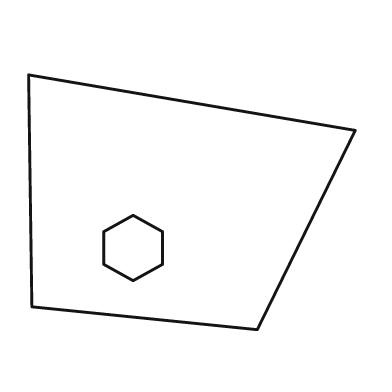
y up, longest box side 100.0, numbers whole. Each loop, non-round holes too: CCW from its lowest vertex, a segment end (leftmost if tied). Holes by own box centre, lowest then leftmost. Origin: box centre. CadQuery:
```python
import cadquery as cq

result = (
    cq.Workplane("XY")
    .moveTo(20.0, -39.0)
    .lineTo(50.0, 22.0)
    .lineTo(-50.0, 39.0)
    .lineTo(-49.0, -32.0)
    .close()
    .moveTo(-18.0, -24.0)
    .lineTo(-9.0, -19.0)
    .lineTo(-9.0, -9.0)
    .lineTo(-18.0, -4.0)
    .lineTo(-27.0, -9.0)
    .lineTo(-27.0, -19.0)
    .close()
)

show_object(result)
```